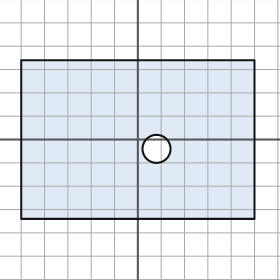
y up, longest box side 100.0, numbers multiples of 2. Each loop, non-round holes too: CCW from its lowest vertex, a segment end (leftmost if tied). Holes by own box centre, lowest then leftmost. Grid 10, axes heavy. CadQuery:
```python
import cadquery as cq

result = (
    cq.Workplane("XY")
    .moveTo(-50.0, -34.0)
    .lineTo(50.0, -34.0)
    .lineTo(50.0, 34.0)
    .lineTo(-50.0, 34.0)
    .close()
    .moveTo(8.0, -4.0)
    .circle(6.0)
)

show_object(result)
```